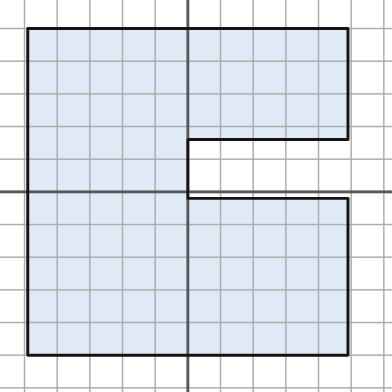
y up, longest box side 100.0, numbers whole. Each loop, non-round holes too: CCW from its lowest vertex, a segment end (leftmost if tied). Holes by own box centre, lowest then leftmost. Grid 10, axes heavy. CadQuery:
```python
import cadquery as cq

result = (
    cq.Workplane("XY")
    .moveTo(-49.0, -50.0)
    .lineTo(49.0, -50.0)
    .lineTo(49.0, -2.0)
    .lineTo(0.0, -2.0)
    .lineTo(0.0, 16.0)
    .lineTo(49.0, 16.0)
    .lineTo(49.0, 50.0)
    .lineTo(-49.0, 50.0)
    .close()
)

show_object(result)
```